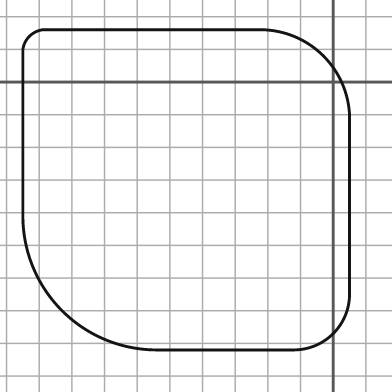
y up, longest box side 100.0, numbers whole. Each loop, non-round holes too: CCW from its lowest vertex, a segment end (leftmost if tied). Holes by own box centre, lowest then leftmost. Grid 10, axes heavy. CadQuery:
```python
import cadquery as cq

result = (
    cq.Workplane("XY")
    .moveTo(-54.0, -82.0)
    .lineTo(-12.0, -82.0)
    .threePointArc((0.0, -77.0), (5.0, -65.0))
    .lineTo(5.0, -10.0)
    .threePointArc((-3.0, 8.0), (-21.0, 16.0))
    .lineTo(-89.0, 16.0)
    .threePointArc((-93.0, 14.0), (-95.0, 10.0))
    .lineTo(-95.0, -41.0)
    .threePointArc((-83.0, -70.0), (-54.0, -82.0))
    .close()
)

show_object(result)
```